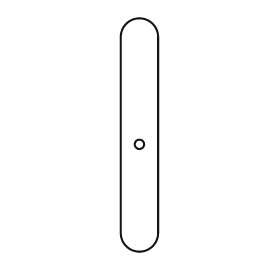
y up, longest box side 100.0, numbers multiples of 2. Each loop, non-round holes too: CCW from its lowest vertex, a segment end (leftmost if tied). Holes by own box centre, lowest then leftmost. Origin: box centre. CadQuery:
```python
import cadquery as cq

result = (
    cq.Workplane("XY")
    .moveTo(-8.0, -42.0)
    .threePointArc((0.0, -50.0), (8.0, -42.0))
    .lineTo(8.0, 42.0)
    .threePointArc((0.0, 50.0), (-8.0, 42.0))
    .close()
    .moveTo(0.0, -4.0)
    .circle(2.0)
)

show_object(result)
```